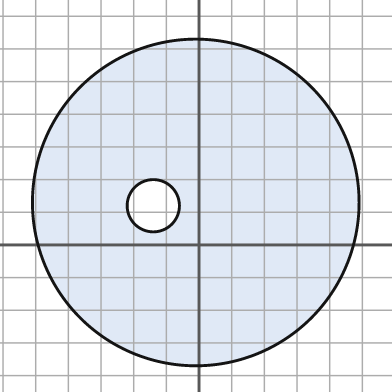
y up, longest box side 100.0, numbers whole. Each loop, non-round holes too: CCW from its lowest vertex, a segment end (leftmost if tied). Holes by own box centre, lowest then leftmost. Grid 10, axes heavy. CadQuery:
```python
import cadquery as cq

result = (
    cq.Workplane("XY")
    .moveTo(-1.0, 13.0)
    .circle(50.0)
    .moveTo(-14.0, 12.0)
    .circle(8.0)
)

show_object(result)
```